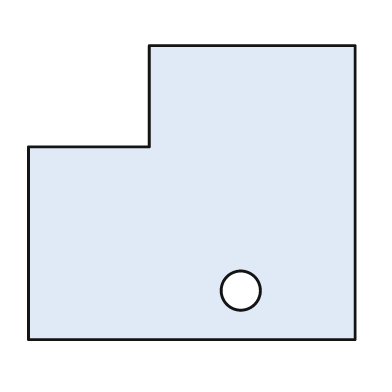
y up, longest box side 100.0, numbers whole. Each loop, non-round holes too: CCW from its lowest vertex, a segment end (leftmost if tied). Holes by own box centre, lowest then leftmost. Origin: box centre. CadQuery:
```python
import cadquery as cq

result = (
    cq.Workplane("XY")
    .moveTo(-50.0, -45.0)
    .lineTo(50.0, -45.0)
    .lineTo(50.0, 45.0)
    .lineTo(-13.0, 45.0)
    .lineTo(-13.0, 14.0)
    .lineTo(-50.0, 14.0)
    .close()
    .moveTo(15.0, -30.0)
    .circle(6.0)
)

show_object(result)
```